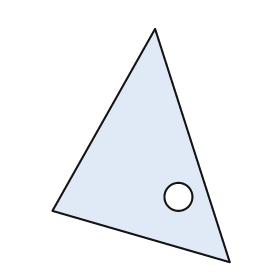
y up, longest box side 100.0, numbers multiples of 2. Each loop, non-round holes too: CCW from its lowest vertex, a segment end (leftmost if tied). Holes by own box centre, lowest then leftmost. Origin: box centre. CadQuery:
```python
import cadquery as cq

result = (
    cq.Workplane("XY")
    .moveTo(38.0, -50.0)
    .lineTo(6.0, 50.0)
    .lineTo(-38.0, -28.0)
    .close()
    .moveTo(16.0, -22.0)
    .circle(6.0)
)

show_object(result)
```